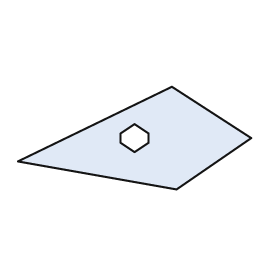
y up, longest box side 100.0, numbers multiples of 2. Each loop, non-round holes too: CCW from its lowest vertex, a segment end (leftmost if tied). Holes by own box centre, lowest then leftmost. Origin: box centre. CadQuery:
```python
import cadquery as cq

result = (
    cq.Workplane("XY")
    .moveTo(18.0, -22.0)
    .lineTo(50.0, 0.0)
    .lineTo(16.0, 22.0)
    .lineTo(-50.0, -10.0)
    .close()
    .moveTo(0.0, -6.0)
    .lineTo(6.0, -2.0)
    .lineTo(6.0, 2.0)
    .lineTo(0.0, 6.0)
    .lineTo(-6.0, 2.0)
    .lineTo(-6.0, -2.0)
    .close()
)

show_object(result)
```